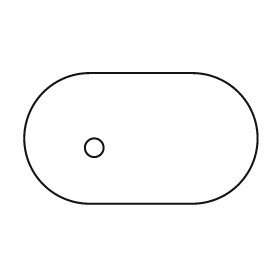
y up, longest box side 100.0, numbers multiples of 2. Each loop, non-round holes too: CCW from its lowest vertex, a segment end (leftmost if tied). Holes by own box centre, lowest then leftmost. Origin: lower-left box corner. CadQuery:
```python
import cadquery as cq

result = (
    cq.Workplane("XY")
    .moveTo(28.0, 0.0)
    .lineTo(72.0, 0.0)
    .threePointArc((100.0, 28.0), (72.0, 56.0))
    .lineTo(28.0, 56.0)
    .threePointArc((0.0, 28.0), (28.0, 0.0))
    .close()
    .moveTo(30.0, 24.0)
    .circle(4.0)
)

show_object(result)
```